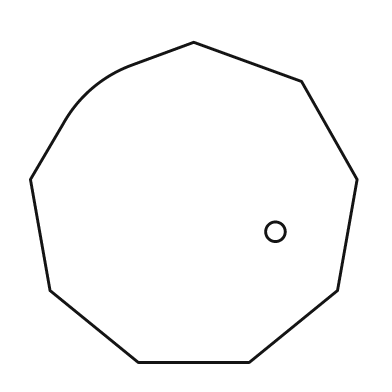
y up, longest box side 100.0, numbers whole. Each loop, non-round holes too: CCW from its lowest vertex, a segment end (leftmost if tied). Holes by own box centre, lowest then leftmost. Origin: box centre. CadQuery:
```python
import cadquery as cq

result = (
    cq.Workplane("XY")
    .moveTo(-17.0, -49.0)
    .lineTo(17.0, -49.0)
    .lineTo(44.0, -27.0)
    .lineTo(50.0, 7.0)
    .lineTo(33.0, 37.0)
    .lineTo(0.0, 49.0)
    .lineTo(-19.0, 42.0)
    .threePointArc((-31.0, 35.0), (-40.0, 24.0))
    .lineTo(-50.0, 7.0)
    .lineTo(-44.0, -27.0)
    .close()
    .moveTo(25.0, -9.0)
    .circle(3.0)
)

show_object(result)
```